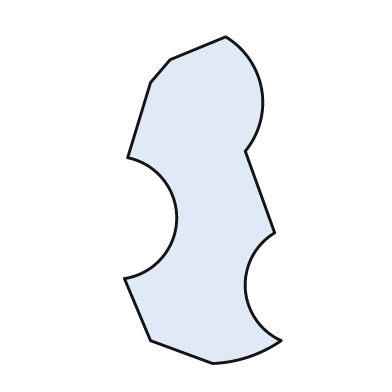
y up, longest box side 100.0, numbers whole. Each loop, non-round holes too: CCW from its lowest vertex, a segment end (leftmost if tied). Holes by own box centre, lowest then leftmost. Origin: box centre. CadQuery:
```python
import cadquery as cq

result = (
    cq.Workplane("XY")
    .moveTo(3.0, -50.0)
    .threePointArc((14.0, -48.0), (24.0, -43.0))
    .threePointArc((13.0, -27.0), (22.0, -10.0))
    .lineTo(13.0, 15.0)
    .threePointArc((18.0, 34.0), (7.0, 50.0))
    .lineTo(-10.0, 43.0)
    .lineTo(-16.0, 36.0)
    .lineTo(-23.0, 13.0)
    .threePointArc((-8.0, -6.0), (-24.0, -24.0))
    .lineTo(-16.0, -43.0)
    .close()
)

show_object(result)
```